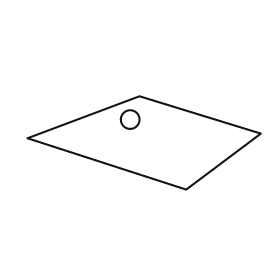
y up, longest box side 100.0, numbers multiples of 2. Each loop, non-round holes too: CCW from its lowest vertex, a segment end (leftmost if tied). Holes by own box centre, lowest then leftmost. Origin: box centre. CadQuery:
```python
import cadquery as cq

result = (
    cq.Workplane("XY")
    .moveTo(18.0, -20.0)
    .lineTo(50.0, 4.0)
    .lineTo(-2.0, 20.0)
    .lineTo(-50.0, 2.0)
    .close()
    .moveTo(-6.0, 10.0)
    .circle(4.0)
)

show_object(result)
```